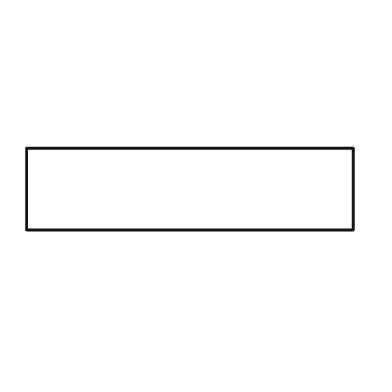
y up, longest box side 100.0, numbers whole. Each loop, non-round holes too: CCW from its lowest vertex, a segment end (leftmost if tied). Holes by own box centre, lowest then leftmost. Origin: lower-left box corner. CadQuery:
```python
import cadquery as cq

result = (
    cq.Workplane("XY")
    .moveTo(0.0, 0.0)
    .lineTo(100.0, 0.0)
    .lineTo(100.0, 25.0)
    .lineTo(0.0, 25.0)
    .close()
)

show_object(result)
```